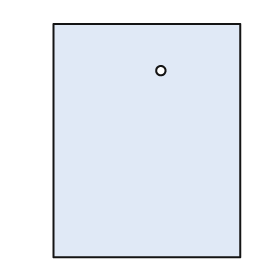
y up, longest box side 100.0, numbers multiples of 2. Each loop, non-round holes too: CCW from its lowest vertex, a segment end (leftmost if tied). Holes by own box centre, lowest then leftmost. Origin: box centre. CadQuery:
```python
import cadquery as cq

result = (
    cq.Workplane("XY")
    .moveTo(-40.0, -50.0)
    .lineTo(40.0, -50.0)
    .lineTo(40.0, 50.0)
    .lineTo(-40.0, 50.0)
    .close()
    .moveTo(6.0, 30.0)
    .circle(2.0)
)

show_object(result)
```